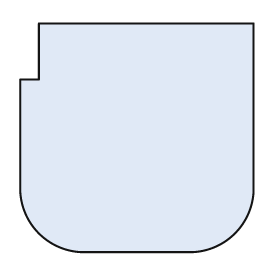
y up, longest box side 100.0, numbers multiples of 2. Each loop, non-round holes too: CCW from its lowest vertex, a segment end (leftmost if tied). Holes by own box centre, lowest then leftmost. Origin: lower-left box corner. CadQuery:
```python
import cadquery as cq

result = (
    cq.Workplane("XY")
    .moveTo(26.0, 0.0)
    .lineTo(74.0, 0.0)
    .threePointArc((92.0, 8.0), (100.0, 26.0))
    .lineTo(100.0, 98.0)
    .lineTo(8.0, 98.0)
    .lineTo(8.0, 74.0)
    .lineTo(0.0, 74.0)
    .lineTo(0.0, 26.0)
    .threePointArc((8.0, 8.0), (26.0, 0.0))
    .close()
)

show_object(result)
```